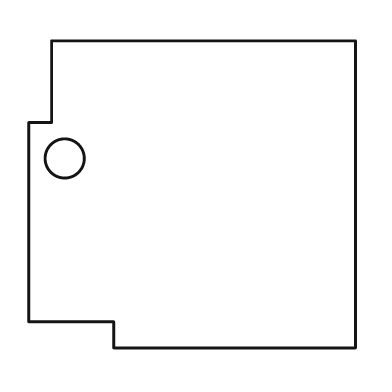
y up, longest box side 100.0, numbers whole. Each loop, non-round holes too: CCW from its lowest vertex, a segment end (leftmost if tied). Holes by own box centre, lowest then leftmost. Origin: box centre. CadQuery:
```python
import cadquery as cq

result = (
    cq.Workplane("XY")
    .moveTo(-24.0, -47.0)
    .lineTo(50.0, -47.0)
    .lineTo(50.0, 47.0)
    .lineTo(-43.0, 47.0)
    .lineTo(-43.0, 22.0)
    .lineTo(-50.0, 22.0)
    .lineTo(-50.0, -39.0)
    .lineTo(-24.0, -39.0)
    .close()
    .moveTo(-39.0, 11.0)
    .circle(6.0)
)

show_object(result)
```